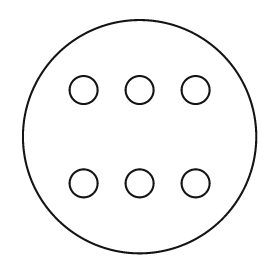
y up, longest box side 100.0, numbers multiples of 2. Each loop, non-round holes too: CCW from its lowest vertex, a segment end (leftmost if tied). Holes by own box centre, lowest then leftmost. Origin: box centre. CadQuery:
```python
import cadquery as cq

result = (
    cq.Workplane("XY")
    .moveTo(0.0, 0.0)
    .circle(50.0)
    .moveTo(-24.0, -20.0)
    .circle(6.0)
    .moveTo(0.0, -20.0)
    .circle(6.0)
    .moveTo(24.0, -20.0)
    .circle(6.0)
    .moveTo(-24.0, 20.0)
    .circle(6.0)
    .moveTo(0.0, 20.0)
    .circle(6.0)
    .moveTo(24.0, 20.0)
    .circle(6.0)
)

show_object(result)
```